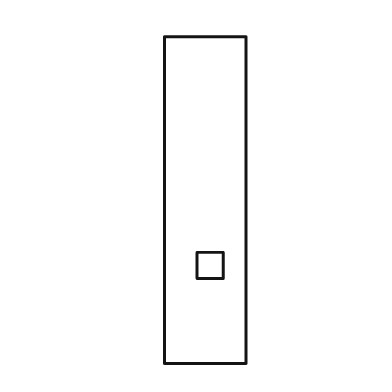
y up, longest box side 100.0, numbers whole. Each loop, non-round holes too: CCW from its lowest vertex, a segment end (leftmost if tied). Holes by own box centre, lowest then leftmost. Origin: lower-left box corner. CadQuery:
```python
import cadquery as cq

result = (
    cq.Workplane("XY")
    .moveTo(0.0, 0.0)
    .lineTo(25.0, 0.0)
    .lineTo(25.0, 100.0)
    .lineTo(0.0, 100.0)
    .close()
    .moveTo(10.0, 26.0)
    .lineTo(18.0, 26.0)
    .lineTo(18.0, 34.0)
    .lineTo(10.0, 34.0)
    .close()
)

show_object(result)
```